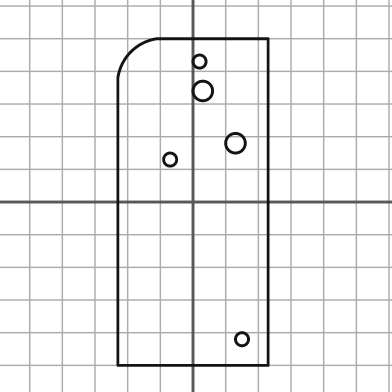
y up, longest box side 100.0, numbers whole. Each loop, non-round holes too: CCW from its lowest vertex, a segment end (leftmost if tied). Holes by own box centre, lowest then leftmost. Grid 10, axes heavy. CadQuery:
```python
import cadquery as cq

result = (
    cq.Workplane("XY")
    .moveTo(-23.0, -50.0)
    .lineTo(23.0, -50.0)
    .lineTo(23.0, 50.0)
    .lineTo(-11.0, 50.0)
    .threePointArc((-19.0, 46.0), (-23.0, 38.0))
    .close()
    .moveTo(15.0, -42.0)
    .circle(2.0)
    .moveTo(-7.0, 13.0)
    .circle(2.0)
    .moveTo(13.0, 18.0)
    .circle(3.0)
    .moveTo(3.0, 34.0)
    .circle(3.0)
    .moveTo(2.0, 43.0)
    .circle(2.0)
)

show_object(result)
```